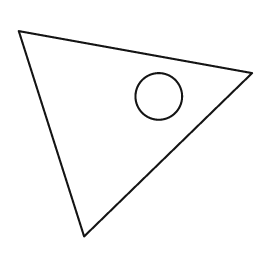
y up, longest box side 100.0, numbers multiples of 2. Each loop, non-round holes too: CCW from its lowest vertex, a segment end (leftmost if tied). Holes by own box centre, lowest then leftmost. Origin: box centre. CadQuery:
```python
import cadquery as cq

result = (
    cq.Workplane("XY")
    .moveTo(-22.0, -44.0)
    .lineTo(50.0, 26.0)
    .lineTo(-50.0, 44.0)
    .close()
    .moveTo(10.0, 16.0)
    .circle(10.0)
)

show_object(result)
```